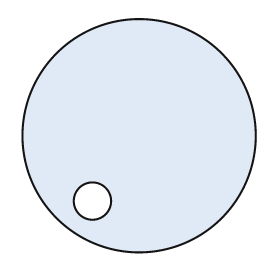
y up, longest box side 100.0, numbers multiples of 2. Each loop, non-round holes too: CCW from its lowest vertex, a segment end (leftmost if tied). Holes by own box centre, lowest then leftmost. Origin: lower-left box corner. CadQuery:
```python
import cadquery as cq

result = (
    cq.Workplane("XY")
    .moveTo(50.0, 50.0)
    .circle(50.0)
    .moveTo(30.0, 22.0)
    .circle(8.0)
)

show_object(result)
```